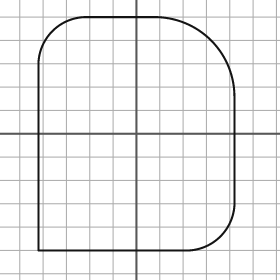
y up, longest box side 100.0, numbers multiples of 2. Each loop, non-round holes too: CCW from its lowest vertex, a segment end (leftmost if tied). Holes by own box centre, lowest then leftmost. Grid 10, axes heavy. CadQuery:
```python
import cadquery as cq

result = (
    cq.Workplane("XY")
    .moveTo(-42.0, -50.0)
    .lineTo(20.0, -50.0)
    .threePointArc((36.0, -44.0), (42.0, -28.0))
    .lineTo(42.0, 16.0)
    .threePointArc((32.0, 40.0), (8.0, 50.0))
    .lineTo(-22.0, 50.0)
    .threePointArc((-36.0, 44.0), (-42.0, 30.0))
    .close()
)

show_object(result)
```